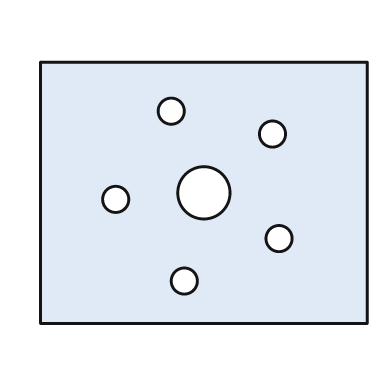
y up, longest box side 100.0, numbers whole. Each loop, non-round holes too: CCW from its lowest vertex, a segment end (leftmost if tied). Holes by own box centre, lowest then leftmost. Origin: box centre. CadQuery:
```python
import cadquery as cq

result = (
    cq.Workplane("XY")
    .moveTo(-50.0, -40.0)
    .lineTo(50.0, -40.0)
    .lineTo(50.0, 40.0)
    .lineTo(-50.0, 40.0)
    .close()
    .moveTo(-6.0, -27.0)
    .circle(4.0)
    .moveTo(23.0, -14.0)
    .circle(4.0)
    .moveTo(-27.0, -2.0)
    .circle(4.0)
    .moveTo(0.0, 0.0)
    .circle(8.0)
    .moveTo(21.0, 18.0)
    .circle(4.0)
    .moveTo(-10.0, 25.0)
    .circle(4.0)
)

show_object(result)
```